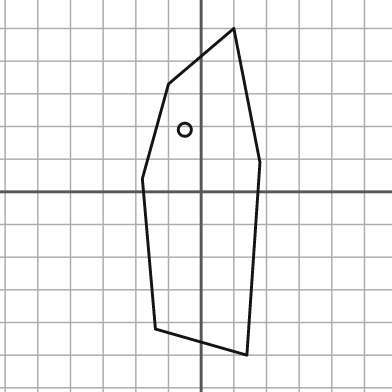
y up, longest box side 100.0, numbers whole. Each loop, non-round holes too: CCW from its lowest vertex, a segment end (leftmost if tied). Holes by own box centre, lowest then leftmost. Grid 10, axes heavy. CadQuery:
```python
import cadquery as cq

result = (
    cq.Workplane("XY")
    .moveTo(14.0, -50.0)
    .lineTo(18.0, 9.0)
    .lineTo(10.0, 50.0)
    .lineTo(-10.0, 33.0)
    .lineTo(-18.0, 4.0)
    .lineTo(-14.0, -42.0)
    .close()
    .moveTo(-5.0, 19.0)
    .circle(2.0)
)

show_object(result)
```